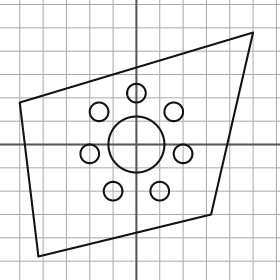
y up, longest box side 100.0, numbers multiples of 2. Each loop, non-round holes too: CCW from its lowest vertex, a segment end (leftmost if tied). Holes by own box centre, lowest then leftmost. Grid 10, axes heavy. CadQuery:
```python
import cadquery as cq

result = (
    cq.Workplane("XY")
    .moveTo(-42.0, -48.0)
    .lineTo(32.0, -30.0)
    .lineTo(50.0, 48.0)
    .lineTo(-50.0, 18.0)
    .close()
    .moveTo(-10.0, -20.0)
    .circle(4.0)
    .moveTo(10.0, -20.0)
    .circle(4.0)
    .moveTo(-20.0, -4.0)
    .circle(4.0)
    .moveTo(20.0, -4.0)
    .circle(4.0)
    .moveTo(0.0, 0.0)
    .circle(12.0)
    .moveTo(-16.0, 14.0)
    .circle(4.0)
    .moveTo(16.0, 14.0)
    .circle(4.0)
    .moveTo(0.0, 22.0)
    .circle(4.0)
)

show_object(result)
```